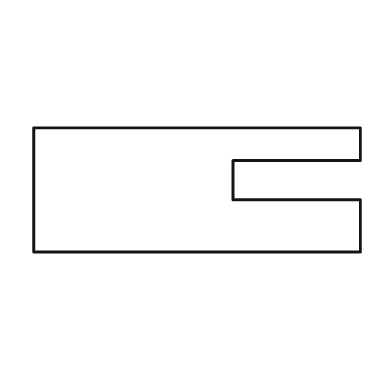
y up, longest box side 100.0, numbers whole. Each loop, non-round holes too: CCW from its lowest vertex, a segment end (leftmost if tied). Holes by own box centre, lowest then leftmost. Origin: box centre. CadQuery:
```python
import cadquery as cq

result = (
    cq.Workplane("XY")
    .moveTo(-50.0, -19.0)
    .lineTo(50.0, -19.0)
    .lineTo(50.0, -3.0)
    .lineTo(11.0, -3.0)
    .lineTo(11.0, 9.0)
    .lineTo(50.0, 9.0)
    .lineTo(50.0, 19.0)
    .lineTo(-50.0, 19.0)
    .close()
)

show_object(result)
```